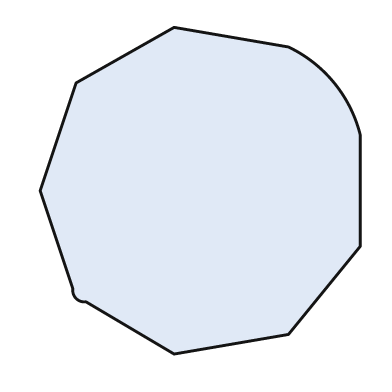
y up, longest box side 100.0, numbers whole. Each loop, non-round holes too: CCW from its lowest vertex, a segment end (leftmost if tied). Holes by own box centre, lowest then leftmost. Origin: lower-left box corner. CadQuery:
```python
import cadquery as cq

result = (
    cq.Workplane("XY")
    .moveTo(41.0, 0.0)
    .lineTo(76.0, 6.0)
    .lineTo(98.0, 33.0)
    .lineTo(98.0, 67.0)
    .threePointArc((90.0, 83.0), (76.0, 94.0))
    .lineTo(41.0, 100.0)
    .lineTo(11.0, 83.0)
    .lineTo(0.0, 50.0)
    .lineTo(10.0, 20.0)
    .threePointArc((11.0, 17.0), (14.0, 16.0))
    .close()
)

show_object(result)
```